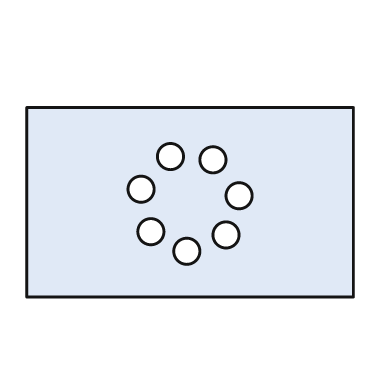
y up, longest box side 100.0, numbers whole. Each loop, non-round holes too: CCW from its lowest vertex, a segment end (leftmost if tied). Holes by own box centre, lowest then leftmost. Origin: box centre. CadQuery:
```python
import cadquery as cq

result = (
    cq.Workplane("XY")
    .moveTo(-50.0, -29.0)
    .lineTo(50.0, -29.0)
    .lineTo(50.0, 29.0)
    .lineTo(-50.0, 29.0)
    .close()
    .moveTo(-1.0, -15.0)
    .circle(4.0)
    .moveTo(11.0, -10.0)
    .circle(4.0)
    .moveTo(-12.0, -9.0)
    .circle(4.0)
    .moveTo(15.0, 2.0)
    .circle(4.0)
    .moveTo(-15.0, 4.0)
    .circle(4.0)
    .moveTo(7.0, 13.0)
    .circle(4.0)
    .moveTo(-6.0, 14.0)
    .circle(4.0)
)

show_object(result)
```